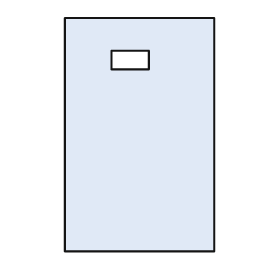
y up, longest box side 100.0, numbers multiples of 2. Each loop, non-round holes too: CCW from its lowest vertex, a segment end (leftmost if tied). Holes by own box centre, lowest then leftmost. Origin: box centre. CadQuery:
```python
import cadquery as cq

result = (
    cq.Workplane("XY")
    .moveTo(-32.0, -50.0)
    .lineTo(32.0, -50.0)
    .lineTo(32.0, 50.0)
    .lineTo(-32.0, 50.0)
    .close()
    .moveTo(-12.0, 28.0)
    .lineTo(4.0, 28.0)
    .lineTo(4.0, 36.0)
    .lineTo(-12.0, 36.0)
    .close()
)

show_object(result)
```